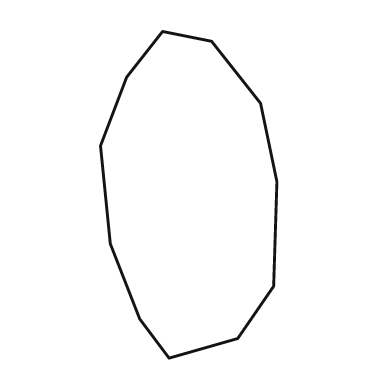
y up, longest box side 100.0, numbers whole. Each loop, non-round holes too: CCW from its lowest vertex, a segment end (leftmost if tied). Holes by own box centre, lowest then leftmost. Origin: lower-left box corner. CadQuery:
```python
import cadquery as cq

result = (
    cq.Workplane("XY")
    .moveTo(21.0, 0.0)
    .lineTo(42.0, 6.0)
    .lineTo(53.0, 22.0)
    .lineTo(54.0, 54.0)
    .lineTo(49.0, 78.0)
    .lineTo(34.0, 97.0)
    .lineTo(19.0, 100.0)
    .lineTo(8.0, 86.0)
    .lineTo(0.0, 65.0)
    .lineTo(3.0, 35.0)
    .lineTo(12.0, 12.0)
    .close()
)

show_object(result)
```